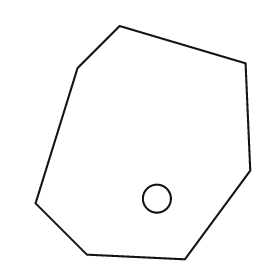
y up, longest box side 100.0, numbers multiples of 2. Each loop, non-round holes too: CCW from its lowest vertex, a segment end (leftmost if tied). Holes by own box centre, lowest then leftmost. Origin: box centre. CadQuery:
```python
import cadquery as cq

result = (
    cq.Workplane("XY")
    .moveTo(18.0, -50.0)
    .lineTo(46.0, -12.0)
    .lineTo(44.0, 34.0)
    .lineTo(-10.0, 50.0)
    .lineTo(-28.0, 32.0)
    .lineTo(-46.0, -26.0)
    .lineTo(-24.0, -48.0)
    .close()
    .moveTo(6.0, -24.0)
    .circle(6.0)
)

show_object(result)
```